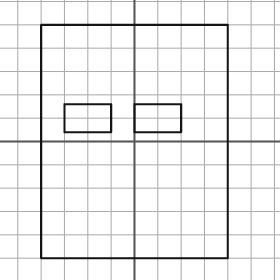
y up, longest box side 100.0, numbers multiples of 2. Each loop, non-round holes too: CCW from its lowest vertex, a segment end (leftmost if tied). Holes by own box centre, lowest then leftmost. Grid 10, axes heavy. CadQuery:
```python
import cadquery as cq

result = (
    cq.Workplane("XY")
    .moveTo(-40.0, -50.0)
    .lineTo(40.0, -50.0)
    .lineTo(40.0, 50.0)
    .lineTo(-40.0, 50.0)
    .close()
    .moveTo(-30.0, 4.0)
    .lineTo(-10.0, 4.0)
    .lineTo(-10.0, 16.0)
    .lineTo(-30.0, 16.0)
    .close()
    .moveTo(0.0, 4.0)
    .lineTo(20.0, 4.0)
    .lineTo(20.0, 16.0)
    .lineTo(0.0, 16.0)
    .close()
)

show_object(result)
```